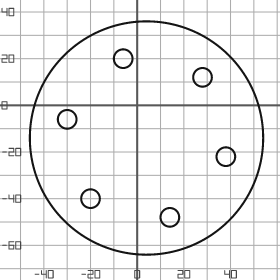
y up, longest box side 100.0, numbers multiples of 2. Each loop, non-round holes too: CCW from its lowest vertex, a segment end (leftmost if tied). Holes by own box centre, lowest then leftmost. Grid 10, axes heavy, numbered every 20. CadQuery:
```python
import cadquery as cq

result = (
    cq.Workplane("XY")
    .moveTo(4.0, -14.0)
    .circle(50.0)
    .moveTo(14.0, -48.0)
    .circle(4.0)
    .moveTo(-20.0, -40.0)
    .circle(4.0)
    .moveTo(38.0, -22.0)
    .circle(4.0)
    .moveTo(-30.0, -6.0)
    .circle(4.0)
    .moveTo(28.0, 12.0)
    .circle(4.0)
    .moveTo(-6.0, 20.0)
    .circle(4.0)
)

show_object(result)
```